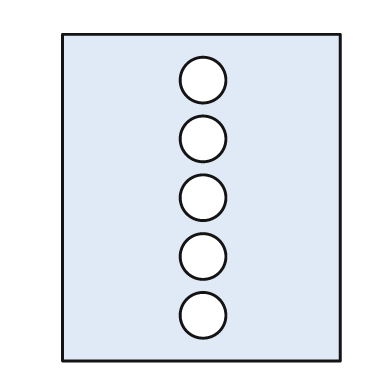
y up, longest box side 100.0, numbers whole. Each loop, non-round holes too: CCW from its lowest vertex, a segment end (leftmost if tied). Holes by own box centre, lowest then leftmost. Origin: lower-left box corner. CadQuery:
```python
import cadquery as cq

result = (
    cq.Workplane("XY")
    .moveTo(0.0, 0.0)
    .lineTo(85.0, 0.0)
    .lineTo(85.0, 100.0)
    .lineTo(0.0, 100.0)
    .close()
    .moveTo(43.0, 14.0)
    .circle(7.0)
    .moveTo(43.0, 32.0)
    .circle(7.0)
    .moveTo(43.0, 50.0)
    .circle(7.0)
    .moveTo(43.0, 68.0)
    .circle(7.0)
    .moveTo(43.0, 86.0)
    .circle(7.0)
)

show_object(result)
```